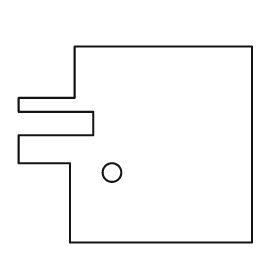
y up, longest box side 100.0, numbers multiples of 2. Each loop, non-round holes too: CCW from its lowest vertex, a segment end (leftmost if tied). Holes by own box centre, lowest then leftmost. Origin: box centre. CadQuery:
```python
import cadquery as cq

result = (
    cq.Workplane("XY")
    .moveTo(-28.0, -42.0)
    .lineTo(50.0, -42.0)
    .lineTo(50.0, 42.0)
    .lineTo(-26.0, 42.0)
    .lineTo(-26.0, 20.0)
    .lineTo(-50.0, 20.0)
    .lineTo(-50.0, 14.0)
    .lineTo(-18.0, 14.0)
    .lineTo(-18.0, 4.0)
    .lineTo(-50.0, 4.0)
    .lineTo(-50.0, -8.0)
    .lineTo(-28.0, -8.0)
    .close()
    .moveTo(-10.0, -12.0)
    .circle(4.0)
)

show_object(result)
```